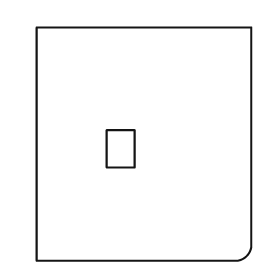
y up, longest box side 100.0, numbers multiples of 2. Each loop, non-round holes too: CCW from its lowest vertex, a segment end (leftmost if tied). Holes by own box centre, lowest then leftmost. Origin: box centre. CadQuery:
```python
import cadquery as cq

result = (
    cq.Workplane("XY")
    .moveTo(-46.0, -50.0)
    .lineTo(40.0, -50.0)
    .threePointArc((44.0, -48.0), (46.0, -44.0))
    .lineTo(46.0, 50.0)
    .lineTo(-46.0, 50.0)
    .close()
    .moveTo(-16.0, -10.0)
    .lineTo(-4.0, -10.0)
    .lineTo(-4.0, 6.0)
    .lineTo(-16.0, 6.0)
    .close()
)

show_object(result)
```